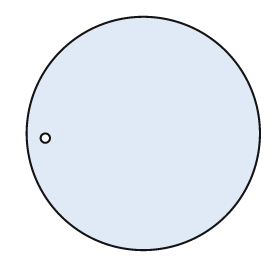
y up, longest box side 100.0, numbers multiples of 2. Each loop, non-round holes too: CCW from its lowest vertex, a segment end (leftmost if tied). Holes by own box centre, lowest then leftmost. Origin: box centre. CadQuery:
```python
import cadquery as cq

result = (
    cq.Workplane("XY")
    .moveTo(0.0, 0.0)
    .circle(50.0)
    .moveTo(-42.0, -2.0)
    .circle(2.0)
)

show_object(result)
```